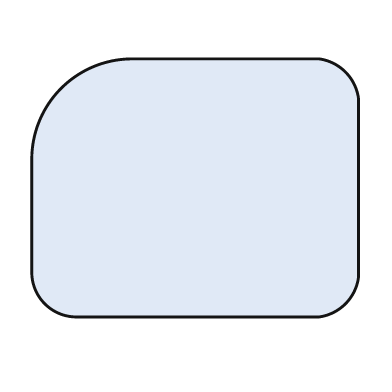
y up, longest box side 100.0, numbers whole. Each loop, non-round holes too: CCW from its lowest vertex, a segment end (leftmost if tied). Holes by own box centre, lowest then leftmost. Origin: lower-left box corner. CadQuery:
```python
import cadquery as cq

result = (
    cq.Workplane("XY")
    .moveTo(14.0, 0.0)
    .lineTo(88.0, 0.0)
    .threePointArc((96.0, 4.0), (100.0, 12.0))
    .lineTo(100.0, 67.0)
    .threePointArc((96.0, 75.0), (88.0, 79.0))
    .lineTo(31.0, 79.0)
    .threePointArc((9.0, 70.0), (0.0, 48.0))
    .lineTo(0.0, 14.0)
    .threePointArc((4.0, 4.0), (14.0, 0.0))
    .close()
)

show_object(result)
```